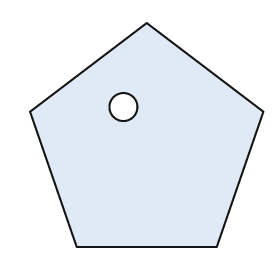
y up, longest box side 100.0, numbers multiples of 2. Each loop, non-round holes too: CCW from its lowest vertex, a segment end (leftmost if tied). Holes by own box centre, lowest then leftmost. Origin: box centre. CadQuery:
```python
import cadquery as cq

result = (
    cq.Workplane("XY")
    .moveTo(-30.0, -48.0)
    .lineTo(30.0, -48.0)
    .lineTo(50.0, 10.0)
    .lineTo(0.0, 48.0)
    .lineTo(-50.0, 10.0)
    .close()
    .moveTo(-10.0, 12.0)
    .circle(6.0)
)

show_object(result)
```